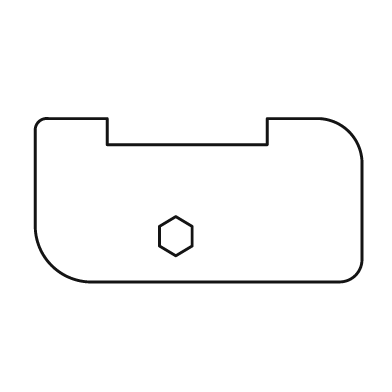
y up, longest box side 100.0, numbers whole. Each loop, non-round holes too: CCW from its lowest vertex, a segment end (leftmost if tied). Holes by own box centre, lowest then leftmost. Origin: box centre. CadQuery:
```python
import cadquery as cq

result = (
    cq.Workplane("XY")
    .moveTo(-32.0, -25.0)
    .lineTo(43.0, -25.0)
    .threePointArc((48.0, -23.0), (50.0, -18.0))
    .lineTo(50.0, 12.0)
    .threePointArc((46.0, 21.0), (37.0, 25.0))
    .lineTo(21.0, 25.0)
    .lineTo(21.0, 17.0)
    .lineTo(-28.0, 17.0)
    .lineTo(-28.0, 25.0)
    .lineTo(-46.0, 25.0)
    .threePointArc((-49.0, 24.0), (-50.0, 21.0))
    .lineTo(-50.0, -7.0)
    .threePointArc((-45.0, -20.0), (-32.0, -25.0))
    .close()
    .moveTo(-7.0, -17.0)
    .lineTo(-2.0, -14.0)
    .lineTo(-2.0, -8.0)
    .lineTo(-7.0, -5.0)
    .lineTo(-12.0, -8.0)
    .lineTo(-12.0, -14.0)
    .close()
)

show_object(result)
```